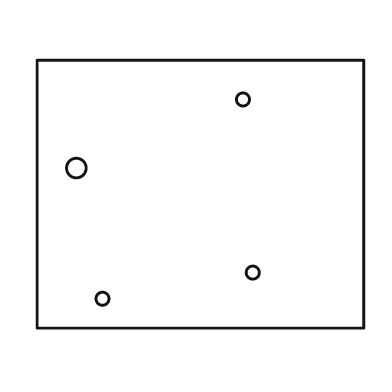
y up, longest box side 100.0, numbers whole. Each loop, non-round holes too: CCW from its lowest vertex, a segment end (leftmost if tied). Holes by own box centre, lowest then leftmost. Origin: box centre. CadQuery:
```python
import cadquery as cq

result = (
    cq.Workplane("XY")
    .moveTo(-50.0, -41.0)
    .lineTo(50.0, -41.0)
    .lineTo(50.0, 41.0)
    .lineTo(-50.0, 41.0)
    .close()
    .moveTo(-30.0, -32.0)
    .circle(2.0)
    .moveTo(16.0, -24.0)
    .circle(2.0)
    .moveTo(-38.0, 8.0)
    .circle(3.0)
    .moveTo(13.0, 29.0)
    .circle(2.0)
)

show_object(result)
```